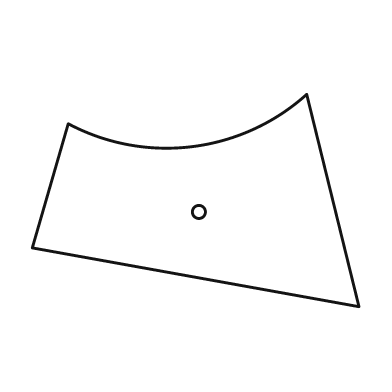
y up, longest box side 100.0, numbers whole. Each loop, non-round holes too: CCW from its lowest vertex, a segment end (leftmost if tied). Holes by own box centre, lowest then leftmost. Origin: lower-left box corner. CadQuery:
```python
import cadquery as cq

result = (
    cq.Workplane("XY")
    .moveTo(100.0, 0.0)
    .lineTo(84.0, 65.0)
    .threePointArc((49.0, 49.0), (11.0, 56.0))
    .lineTo(0.0, 18.0)
    .close()
    .moveTo(51.0, 29.0)
    .circle(2.0)
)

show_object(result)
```